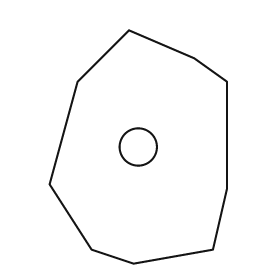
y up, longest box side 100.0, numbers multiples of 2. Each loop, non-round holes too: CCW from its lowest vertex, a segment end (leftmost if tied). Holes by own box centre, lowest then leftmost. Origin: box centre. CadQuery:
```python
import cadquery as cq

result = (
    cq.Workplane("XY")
    .moveTo(-2.0, -50.0)
    .lineTo(32.0, -44.0)
    .lineTo(38.0, -18.0)
    .lineTo(38.0, 28.0)
    .lineTo(24.0, 38.0)
    .lineTo(-4.0, 50.0)
    .lineTo(-26.0, 28.0)
    .lineTo(-38.0, -16.0)
    .lineTo(-20.0, -44.0)
    .close()
    .moveTo(0.0, 0.0)
    .circle(8.0)
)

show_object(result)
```